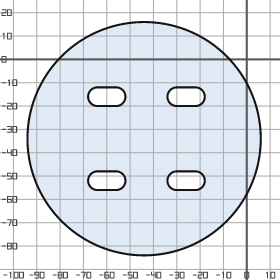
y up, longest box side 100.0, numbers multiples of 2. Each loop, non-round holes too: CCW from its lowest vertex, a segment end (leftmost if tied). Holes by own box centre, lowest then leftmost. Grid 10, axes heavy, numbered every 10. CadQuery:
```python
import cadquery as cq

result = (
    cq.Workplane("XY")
    .moveTo(-44.0, -34.0)
    .circle(50.0)
    .moveTo(-64.0, -56.0)
    .lineTo(-56.0, -56.0)
    .threePointArc((-52.0, -52.0), (-56.0, -48.0))
    .lineTo(-64.0, -48.0)
    .threePointArc((-68.0, -52.0), (-64.0, -56.0))
    .close()
    .moveTo(-30.0, -56.0)
    .lineTo(-22.0, -56.0)
    .threePointArc((-18.0, -52.0), (-22.0, -48.0))
    .lineTo(-30.0, -48.0)
    .threePointArc((-34.0, -52.0), (-30.0, -56.0))
    .close()
    .moveTo(-64.0, -20.0)
    .lineTo(-56.0, -20.0)
    .threePointArc((-52.0, -16.0), (-56.0, -12.0))
    .lineTo(-64.0, -12.0)
    .threePointArc((-68.0, -16.0), (-64.0, -20.0))
    .close()
    .moveTo(-30.0, -20.0)
    .lineTo(-22.0, -20.0)
    .threePointArc((-18.0, -16.0), (-22.0, -12.0))
    .lineTo(-30.0, -12.0)
    .threePointArc((-34.0, -16.0), (-30.0, -20.0))
    .close()
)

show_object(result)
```